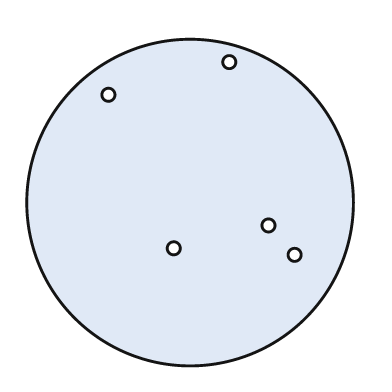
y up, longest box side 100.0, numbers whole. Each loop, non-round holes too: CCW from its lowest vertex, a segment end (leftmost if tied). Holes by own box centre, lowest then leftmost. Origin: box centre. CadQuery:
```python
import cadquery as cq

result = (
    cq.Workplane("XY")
    .moveTo(0.0, 0.0)
    .circle(50.0)
    .moveTo(32.0, -16.0)
    .circle(2.0)
    .moveTo(-5.0, -14.0)
    .circle(2.0)
    .moveTo(24.0, -7.0)
    .circle(2.0)
    .moveTo(-25.0, 33.0)
    .circle(2.0)
    .moveTo(12.0, 43.0)
    .circle(2.0)
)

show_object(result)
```